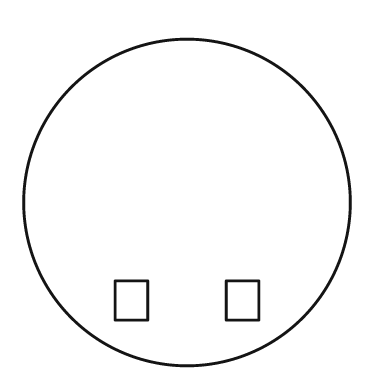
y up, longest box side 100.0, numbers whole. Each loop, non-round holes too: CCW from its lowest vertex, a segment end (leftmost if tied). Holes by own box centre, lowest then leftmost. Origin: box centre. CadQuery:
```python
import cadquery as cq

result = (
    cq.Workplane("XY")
    .moveTo(0.0, 0.0)
    .circle(50.0)
    .moveTo(-22.0, -36.0)
    .lineTo(-12.0, -36.0)
    .lineTo(-12.0, -24.0)
    .lineTo(-22.0, -24.0)
    .close()
    .moveTo(12.0, -36.0)
    .lineTo(22.0, -36.0)
    .lineTo(22.0, -24.0)
    .lineTo(12.0, -24.0)
    .close()
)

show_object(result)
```